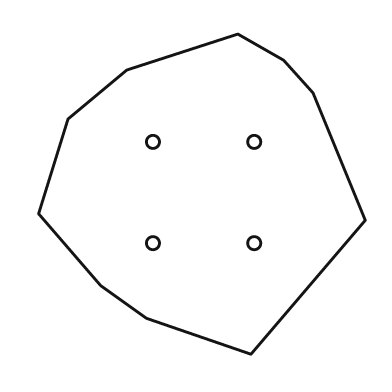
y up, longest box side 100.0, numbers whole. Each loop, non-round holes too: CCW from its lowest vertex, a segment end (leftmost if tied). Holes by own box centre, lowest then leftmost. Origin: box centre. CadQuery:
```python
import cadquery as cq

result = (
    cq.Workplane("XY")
    .moveTo(15.0, -49.0)
    .lineTo(50.0, -8.0)
    .lineTo(34.0, 31.0)
    .lineTo(25.0, 41.0)
    .lineTo(11.0, 49.0)
    .lineTo(-23.0, 38.0)
    .lineTo(-41.0, 23.0)
    .lineTo(-50.0, -6.0)
    .lineTo(-31.0, -28.0)
    .lineTo(-17.0, -38.0)
    .close()
    .moveTo(-15.0, -15.0)
    .circle(2.0)
    .moveTo(16.0, -15.0)
    .circle(2.0)
    .moveTo(-15.0, 16.0)
    .circle(2.0)
    .moveTo(16.0, 16.0)
    .circle(2.0)
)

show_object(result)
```